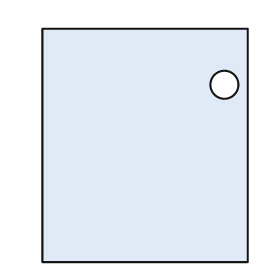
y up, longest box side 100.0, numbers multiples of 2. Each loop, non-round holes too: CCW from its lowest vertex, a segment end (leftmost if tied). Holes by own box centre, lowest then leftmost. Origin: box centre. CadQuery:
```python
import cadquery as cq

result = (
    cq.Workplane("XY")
    .moveTo(-44.0, -50.0)
    .lineTo(44.0, -50.0)
    .lineTo(44.0, 50.0)
    .lineTo(-44.0, 50.0)
    .close()
    .moveTo(34.0, 26.0)
    .circle(6.0)
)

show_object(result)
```